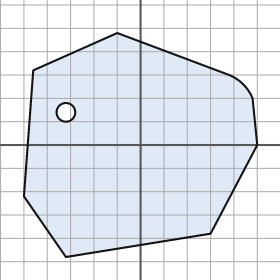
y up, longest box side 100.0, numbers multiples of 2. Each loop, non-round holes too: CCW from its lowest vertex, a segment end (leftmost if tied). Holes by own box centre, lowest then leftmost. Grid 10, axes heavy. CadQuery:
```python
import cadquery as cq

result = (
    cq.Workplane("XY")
    .moveTo(-32.0, -48.0)
    .lineTo(30.0, -38.0)
    .lineTo(50.0, 0.0)
    .lineTo(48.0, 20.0)
    .threePointArc((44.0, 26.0), (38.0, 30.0))
    .lineTo(-10.0, 48.0)
    .lineTo(-46.0, 32.0)
    .lineTo(-50.0, -22.0)
    .close()
    .moveTo(-32.0, 14.0)
    .circle(4.0)
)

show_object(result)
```